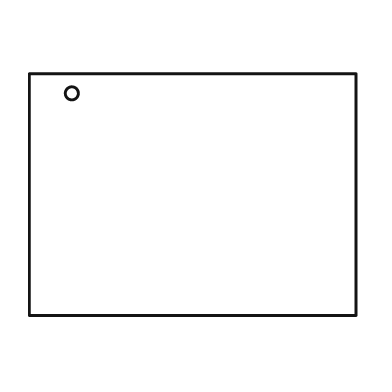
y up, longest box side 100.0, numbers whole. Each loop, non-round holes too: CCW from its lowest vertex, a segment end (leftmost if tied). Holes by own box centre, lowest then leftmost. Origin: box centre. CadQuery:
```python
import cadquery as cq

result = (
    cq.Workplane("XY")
    .moveTo(-50.0, -37.0)
    .lineTo(50.0, -37.0)
    .lineTo(50.0, 37.0)
    .lineTo(-50.0, 37.0)
    .close()
    .moveTo(-37.0, 31.0)
    .circle(2.0)
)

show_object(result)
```